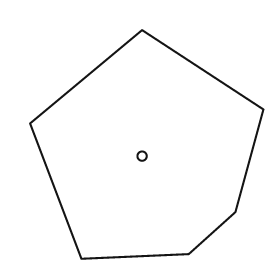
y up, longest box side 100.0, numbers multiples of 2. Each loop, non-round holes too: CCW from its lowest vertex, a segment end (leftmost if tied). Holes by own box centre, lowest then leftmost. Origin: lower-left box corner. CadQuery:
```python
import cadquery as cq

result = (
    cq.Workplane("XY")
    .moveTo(22.0, 0.0)
    .lineTo(68.0, 2.0)
    .lineTo(88.0, 20.0)
    .lineTo(100.0, 64.0)
    .lineTo(48.0, 98.0)
    .lineTo(0.0, 58.0)
    .close()
    .moveTo(48.0, 44.0)
    .circle(2.0)
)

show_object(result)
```